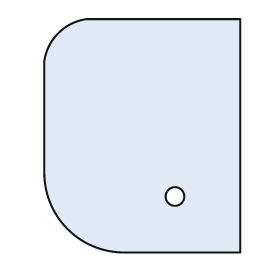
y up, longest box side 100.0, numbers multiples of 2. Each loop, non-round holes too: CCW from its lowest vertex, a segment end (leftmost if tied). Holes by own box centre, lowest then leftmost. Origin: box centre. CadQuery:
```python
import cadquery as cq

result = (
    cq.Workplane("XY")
    .moveTo(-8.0, -50.0)
    .lineTo(42.0, -50.0)
    .lineTo(42.0, 50.0)
    .lineTo(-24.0, 50.0)
    .threePointArc((-36.0, 44.0), (-42.0, 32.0))
    .lineTo(-42.0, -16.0)
    .threePointArc((-32.0, -40.0), (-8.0, -50.0))
    .close()
    .moveTo(14.0, -26.0)
    .circle(4.0)
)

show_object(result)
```